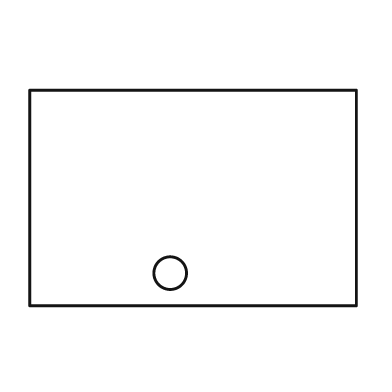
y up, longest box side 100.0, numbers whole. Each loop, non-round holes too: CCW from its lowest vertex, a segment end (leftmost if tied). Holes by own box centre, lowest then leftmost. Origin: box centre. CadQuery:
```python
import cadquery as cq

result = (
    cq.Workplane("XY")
    .moveTo(-50.0, -33.0)
    .lineTo(50.0, -33.0)
    .lineTo(50.0, 33.0)
    .lineTo(-50.0, 33.0)
    .close()
    .moveTo(-7.0, -23.0)
    .circle(5.0)
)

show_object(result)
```